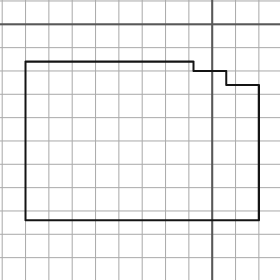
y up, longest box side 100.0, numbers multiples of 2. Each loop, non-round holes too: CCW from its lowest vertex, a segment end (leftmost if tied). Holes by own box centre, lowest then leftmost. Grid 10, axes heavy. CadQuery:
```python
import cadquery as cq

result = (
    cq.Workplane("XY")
    .moveTo(-80.0, -84.0)
    .lineTo(20.0, -84.0)
    .lineTo(20.0, -26.0)
    .lineTo(6.0, -26.0)
    .lineTo(6.0, -20.0)
    .lineTo(-8.0, -20.0)
    .lineTo(-8.0, -16.0)
    .lineTo(-80.0, -16.0)
    .close()
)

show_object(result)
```